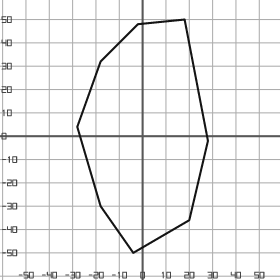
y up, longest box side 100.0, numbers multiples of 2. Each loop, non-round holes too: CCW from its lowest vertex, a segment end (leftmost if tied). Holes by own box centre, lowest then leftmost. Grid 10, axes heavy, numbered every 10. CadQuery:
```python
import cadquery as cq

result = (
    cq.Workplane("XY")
    .moveTo(-4.0, -50.0)
    .lineTo(20.0, -36.0)
    .lineTo(28.0, -2.0)
    .lineTo(18.0, 50.0)
    .lineTo(-2.0, 48.0)
    .lineTo(-18.0, 32.0)
    .lineTo(-28.0, 4.0)
    .lineTo(-18.0, -30.0)
    .close()
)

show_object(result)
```